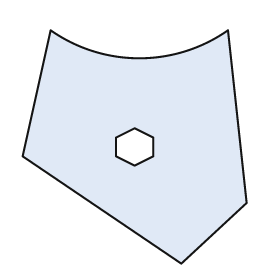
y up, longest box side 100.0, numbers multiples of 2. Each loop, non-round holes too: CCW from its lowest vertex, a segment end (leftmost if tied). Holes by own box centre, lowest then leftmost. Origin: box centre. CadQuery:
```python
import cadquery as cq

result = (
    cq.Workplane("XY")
    .moveTo(20.0, -50.0)
    .lineTo(48.0, -24.0)
    .lineTo(40.0, 50.0)
    .threePointArc((2.0, 38.0), (-36.0, 50.0))
    .lineTo(-48.0, -4.0)
    .close()
    .moveTo(0.0, -8.0)
    .lineTo(8.0, -4.0)
    .lineTo(8.0, 4.0)
    .lineTo(0.0, 8.0)
    .lineTo(-8.0, 4.0)
    .lineTo(-8.0, -4.0)
    .close()
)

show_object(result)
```